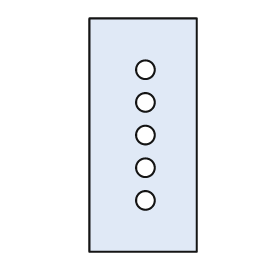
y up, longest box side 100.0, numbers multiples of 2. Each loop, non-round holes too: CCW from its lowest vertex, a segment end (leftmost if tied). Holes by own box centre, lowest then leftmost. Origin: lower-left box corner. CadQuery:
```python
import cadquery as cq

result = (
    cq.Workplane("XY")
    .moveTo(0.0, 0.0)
    .lineTo(46.0, 0.0)
    .lineTo(46.0, 100.0)
    .lineTo(0.0, 100.0)
    .close()
    .moveTo(24.0, 22.0)
    .circle(4.0)
    .moveTo(24.0, 36.0)
    .circle(4.0)
    .moveTo(24.0, 50.0)
    .circle(4.0)
    .moveTo(24.0, 64.0)
    .circle(4.0)
    .moveTo(24.0, 78.0)
    .circle(4.0)
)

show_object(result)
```